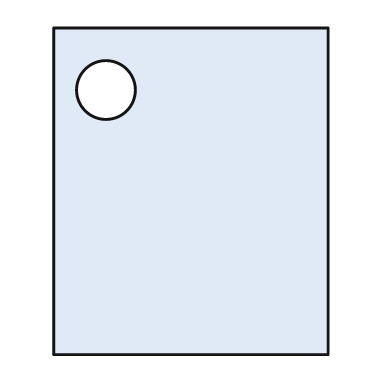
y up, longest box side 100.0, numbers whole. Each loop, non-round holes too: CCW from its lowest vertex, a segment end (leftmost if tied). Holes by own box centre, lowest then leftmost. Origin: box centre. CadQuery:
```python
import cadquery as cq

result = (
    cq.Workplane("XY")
    .moveTo(-42.0, -50.0)
    .lineTo(42.0, -50.0)
    .lineTo(42.0, 50.0)
    .lineTo(-42.0, 50.0)
    .close()
    .moveTo(-26.0, 31.0)
    .circle(9.0)
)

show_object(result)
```